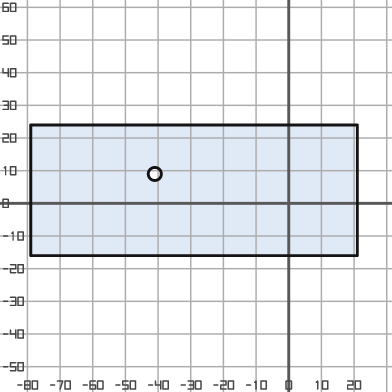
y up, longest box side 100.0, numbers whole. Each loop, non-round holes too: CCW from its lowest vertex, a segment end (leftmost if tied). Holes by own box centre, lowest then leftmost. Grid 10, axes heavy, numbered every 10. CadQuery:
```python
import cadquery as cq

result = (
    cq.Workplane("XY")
    .moveTo(-79.0, -16.0)
    .lineTo(21.0, -16.0)
    .lineTo(21.0, 24.0)
    .lineTo(-79.0, 24.0)
    .close()
    .moveTo(-41.0, 9.0)
    .circle(2.0)
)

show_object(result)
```